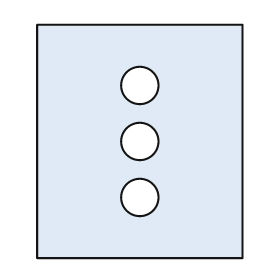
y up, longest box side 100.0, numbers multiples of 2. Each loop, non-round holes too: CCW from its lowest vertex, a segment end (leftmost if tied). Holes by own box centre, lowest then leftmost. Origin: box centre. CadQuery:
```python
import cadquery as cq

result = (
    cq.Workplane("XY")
    .moveTo(-44.0, -50.0)
    .lineTo(44.0, -50.0)
    .lineTo(44.0, 50.0)
    .lineTo(-44.0, 50.0)
    .close()
    .moveTo(0.0, -24.0)
    .circle(8.0)
    .moveTo(0.0, 0.0)
    .circle(8.0)
    .moveTo(0.0, 24.0)
    .circle(8.0)
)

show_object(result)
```